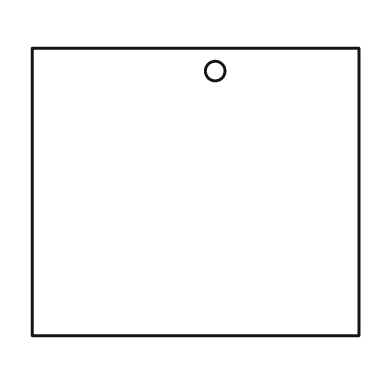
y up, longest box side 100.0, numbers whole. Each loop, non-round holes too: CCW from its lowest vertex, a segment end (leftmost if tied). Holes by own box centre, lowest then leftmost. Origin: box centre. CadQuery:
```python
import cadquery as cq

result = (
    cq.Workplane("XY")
    .moveTo(-50.0, -44.0)
    .lineTo(50.0, -44.0)
    .lineTo(50.0, 44.0)
    .lineTo(-50.0, 44.0)
    .close()
    .moveTo(6.0, 37.0)
    .circle(3.0)
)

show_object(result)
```